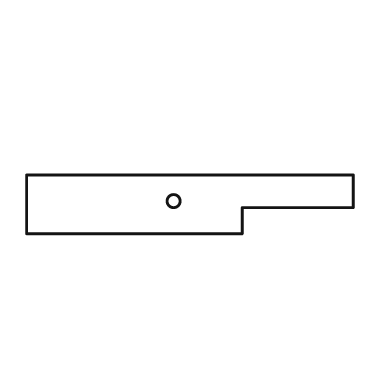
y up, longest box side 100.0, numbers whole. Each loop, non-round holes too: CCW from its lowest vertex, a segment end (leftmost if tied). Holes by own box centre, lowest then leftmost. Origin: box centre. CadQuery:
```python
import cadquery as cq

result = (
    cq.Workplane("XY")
    .moveTo(-50.0, -9.0)
    .lineTo(16.0, -9.0)
    .lineTo(16.0, -1.0)
    .lineTo(50.0, -1.0)
    .lineTo(50.0, 9.0)
    .lineTo(-50.0, 9.0)
    .close()
    .moveTo(-5.0, 1.0)
    .circle(2.0)
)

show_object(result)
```